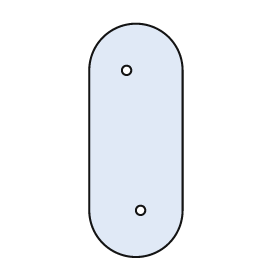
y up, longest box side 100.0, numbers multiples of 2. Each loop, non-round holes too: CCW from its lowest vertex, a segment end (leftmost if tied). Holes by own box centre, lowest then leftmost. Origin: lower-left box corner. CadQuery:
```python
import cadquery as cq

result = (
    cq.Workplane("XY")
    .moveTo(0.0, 20.0)
    .threePointArc((20.0, 0.0), (40.0, 20.0))
    .lineTo(40.0, 80.0)
    .threePointArc((20.0, 100.0), (0.0, 80.0))
    .close()
    .moveTo(22.0, 20.0)
    .circle(2.0)
    .moveTo(16.0, 80.0)
    .circle(2.0)
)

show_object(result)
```